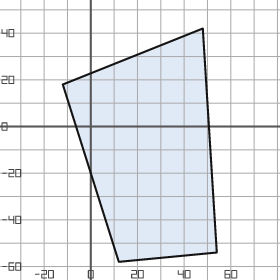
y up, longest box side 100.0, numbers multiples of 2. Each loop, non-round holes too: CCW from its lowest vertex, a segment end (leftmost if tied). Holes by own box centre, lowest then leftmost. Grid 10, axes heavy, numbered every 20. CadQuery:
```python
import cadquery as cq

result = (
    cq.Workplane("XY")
    .moveTo(12.0, -58.0)
    .lineTo(54.0, -54.0)
    .lineTo(48.0, 42.0)
    .lineTo(-12.0, 18.0)
    .close()
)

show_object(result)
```